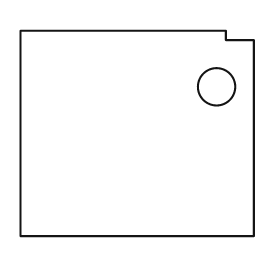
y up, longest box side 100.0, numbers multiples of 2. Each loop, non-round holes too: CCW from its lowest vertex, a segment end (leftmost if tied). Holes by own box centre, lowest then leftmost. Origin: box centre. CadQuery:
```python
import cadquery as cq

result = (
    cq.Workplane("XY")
    .moveTo(-50.0, -44.0)
    .lineTo(50.0, -44.0)
    .lineTo(50.0, 40.0)
    .lineTo(38.0, 40.0)
    .lineTo(38.0, 44.0)
    .lineTo(-50.0, 44.0)
    .close()
    .moveTo(34.0, 20.0)
    .circle(8.0)
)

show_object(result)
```